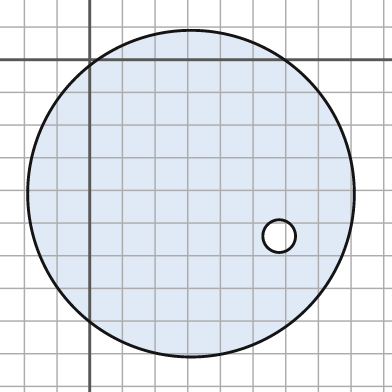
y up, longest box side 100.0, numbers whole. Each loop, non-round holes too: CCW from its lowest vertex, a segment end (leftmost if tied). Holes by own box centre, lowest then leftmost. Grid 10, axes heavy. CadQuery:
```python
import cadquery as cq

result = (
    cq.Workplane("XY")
    .moveTo(31.0, -41.0)
    .circle(50.0)
    .moveTo(58.0, -54.0)
    .circle(5.0)
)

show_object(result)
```